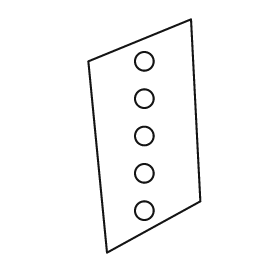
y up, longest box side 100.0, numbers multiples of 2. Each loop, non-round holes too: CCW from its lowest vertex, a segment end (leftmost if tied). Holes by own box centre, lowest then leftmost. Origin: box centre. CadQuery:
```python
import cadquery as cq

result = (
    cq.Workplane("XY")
    .moveTo(-16.0, -50.0)
    .lineTo(24.0, -28.0)
    .lineTo(20.0, 50.0)
    .lineTo(-24.0, 32.0)
    .close()
    .moveTo(0.0, -32.0)
    .circle(4.0)
    .moveTo(0.0, -16.0)
    .circle(4.0)
    .moveTo(0.0, 0.0)
    .circle(4.0)
    .moveTo(0.0, 16.0)
    .circle(4.0)
    .moveTo(0.0, 32.0)
    .circle(4.0)
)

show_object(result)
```